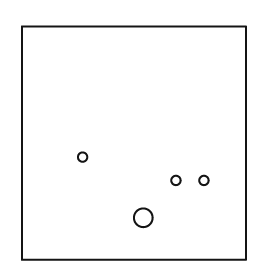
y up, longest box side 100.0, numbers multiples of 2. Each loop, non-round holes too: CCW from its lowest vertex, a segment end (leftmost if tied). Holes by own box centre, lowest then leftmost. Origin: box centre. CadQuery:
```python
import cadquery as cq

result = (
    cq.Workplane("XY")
    .moveTo(-48.0, -50.0)
    .lineTo(48.0, -50.0)
    .lineTo(48.0, 50.0)
    .lineTo(-48.0, 50.0)
    .close()
    .moveTo(4.0, -32.0)
    .circle(4.0)
    .moveTo(18.0, -16.0)
    .circle(2.0)
    .moveTo(30.0, -16.0)
    .circle(2.0)
    .moveTo(-22.0, -6.0)
    .circle(2.0)
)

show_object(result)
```